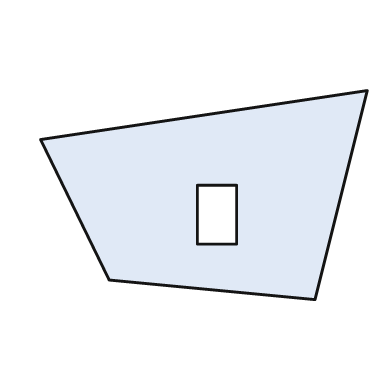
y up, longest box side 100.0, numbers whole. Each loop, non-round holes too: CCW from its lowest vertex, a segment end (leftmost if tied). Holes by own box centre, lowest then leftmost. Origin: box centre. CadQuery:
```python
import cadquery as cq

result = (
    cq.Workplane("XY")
    .moveTo(34.0, -32.0)
    .lineTo(50.0, 32.0)
    .lineTo(-50.0, 17.0)
    .lineTo(-29.0, -26.0)
    .close()
    .moveTo(-2.0, -15.0)
    .lineTo(10.0, -15.0)
    .lineTo(10.0, 3.0)
    .lineTo(-2.0, 3.0)
    .close()
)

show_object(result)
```